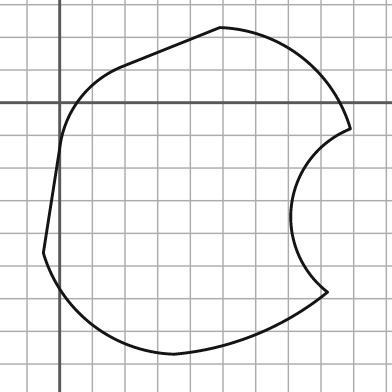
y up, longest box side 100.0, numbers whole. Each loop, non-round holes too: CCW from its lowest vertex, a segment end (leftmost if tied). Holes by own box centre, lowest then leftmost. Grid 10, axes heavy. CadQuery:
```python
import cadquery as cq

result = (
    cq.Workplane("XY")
    .moveTo(35.0, -77.0)
    .threePointArc((60.0, -71.0), (82.0, -58.0))
    .threePointArc((71.0, -31.0), (89.0, -8.0))
    .threePointArc((74.0, 14.0), (49.0, 23.0))
    .lineTo(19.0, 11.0)
    .threePointArc((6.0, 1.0), (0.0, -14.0))
    .lineTo(-5.0, -46.0)
    .threePointArc((10.0, -68.0), (35.0, -77.0))
    .close()
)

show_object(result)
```